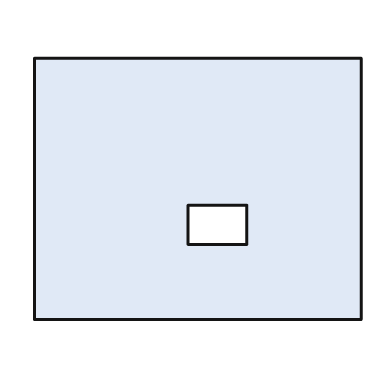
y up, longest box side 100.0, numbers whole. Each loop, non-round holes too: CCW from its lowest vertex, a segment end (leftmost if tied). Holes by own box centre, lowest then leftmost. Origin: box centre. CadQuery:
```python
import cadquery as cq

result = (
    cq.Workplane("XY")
    .moveTo(-50.0, -40.0)
    .lineTo(50.0, -40.0)
    .lineTo(50.0, 40.0)
    .lineTo(-50.0, 40.0)
    .close()
    .moveTo(-3.0, -17.0)
    .lineTo(15.0, -17.0)
    .lineTo(15.0, -5.0)
    .lineTo(-3.0, -5.0)
    .close()
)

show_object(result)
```